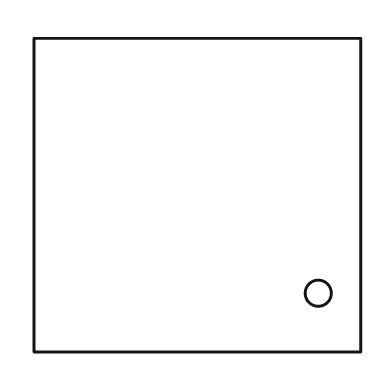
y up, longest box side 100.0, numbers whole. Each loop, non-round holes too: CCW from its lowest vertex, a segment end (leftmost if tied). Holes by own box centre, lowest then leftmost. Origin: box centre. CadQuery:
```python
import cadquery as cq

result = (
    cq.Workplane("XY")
    .moveTo(-50.0, -48.0)
    .lineTo(50.0, -48.0)
    .lineTo(50.0, 48.0)
    .lineTo(-50.0, 48.0)
    .close()
    .moveTo(37.0, -30.0)
    .circle(4.0)
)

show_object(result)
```